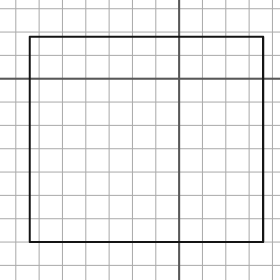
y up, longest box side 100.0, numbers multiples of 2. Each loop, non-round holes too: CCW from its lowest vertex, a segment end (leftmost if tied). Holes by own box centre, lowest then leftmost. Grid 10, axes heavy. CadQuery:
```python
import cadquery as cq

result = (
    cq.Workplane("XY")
    .moveTo(-64.0, -70.0)
    .lineTo(36.0, -70.0)
    .lineTo(36.0, 18.0)
    .lineTo(-64.0, 18.0)
    .close()
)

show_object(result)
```